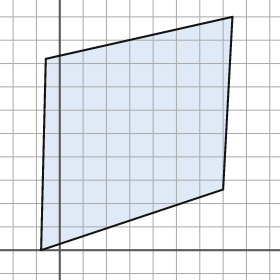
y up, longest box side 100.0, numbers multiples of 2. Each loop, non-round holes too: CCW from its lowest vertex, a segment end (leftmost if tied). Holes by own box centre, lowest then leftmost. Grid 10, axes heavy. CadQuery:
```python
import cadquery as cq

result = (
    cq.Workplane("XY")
    .moveTo(-8.0, 0.0)
    .lineTo(70.0, 26.0)
    .lineTo(74.0, 100.0)
    .lineTo(-6.0, 82.0)
    .close()
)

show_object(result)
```